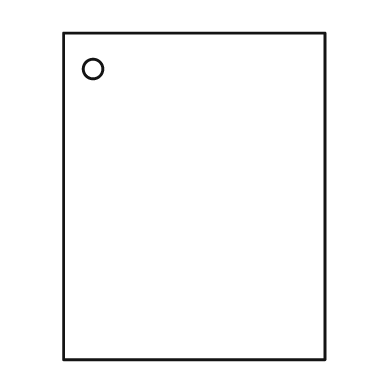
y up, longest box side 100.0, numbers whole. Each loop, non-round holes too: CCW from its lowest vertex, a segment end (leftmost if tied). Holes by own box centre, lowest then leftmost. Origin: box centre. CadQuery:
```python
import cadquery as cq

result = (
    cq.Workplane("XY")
    .moveTo(-40.0, -50.0)
    .lineTo(40.0, -50.0)
    .lineTo(40.0, 50.0)
    .lineTo(-40.0, 50.0)
    .close()
    .moveTo(-31.0, 39.0)
    .circle(3.0)
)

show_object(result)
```